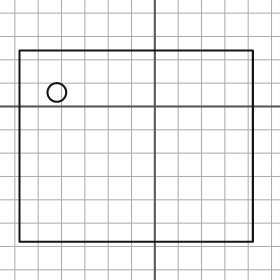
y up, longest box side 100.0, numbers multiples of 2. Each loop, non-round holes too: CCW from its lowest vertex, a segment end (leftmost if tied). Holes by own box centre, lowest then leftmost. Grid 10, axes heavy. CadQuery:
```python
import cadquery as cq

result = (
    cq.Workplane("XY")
    .moveTo(-58.0, -58.0)
    .lineTo(42.0, -58.0)
    .lineTo(42.0, 24.0)
    .lineTo(-58.0, 24.0)
    .close()
    .moveTo(-42.0, 6.0)
    .circle(4.0)
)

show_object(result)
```